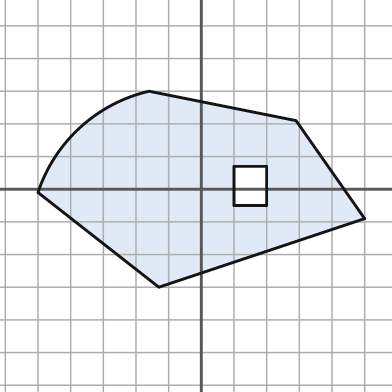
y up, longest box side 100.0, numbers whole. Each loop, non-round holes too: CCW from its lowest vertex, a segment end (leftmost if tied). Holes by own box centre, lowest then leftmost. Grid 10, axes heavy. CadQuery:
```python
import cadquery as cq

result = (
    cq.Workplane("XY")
    .moveTo(-13.0, -30.0)
    .lineTo(50.0, -9.0)
    .lineTo(29.0, 21.0)
    .lineTo(-16.0, 30.0)
    .threePointArc((-37.0, 19.0), (-50.0, -1.0))
    .close()
    .moveTo(10.0, -5.0)
    .lineTo(20.0, -5.0)
    .lineTo(20.0, 7.0)
    .lineTo(10.0, 7.0)
    .close()
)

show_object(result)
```